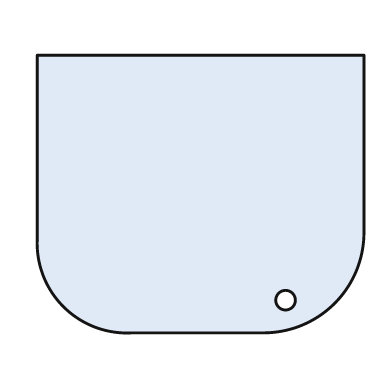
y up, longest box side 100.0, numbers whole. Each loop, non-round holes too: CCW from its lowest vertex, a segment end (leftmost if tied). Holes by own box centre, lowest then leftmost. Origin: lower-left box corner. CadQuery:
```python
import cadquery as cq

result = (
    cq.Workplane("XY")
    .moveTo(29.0, 0.0)
    .lineTo(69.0, 0.0)
    .threePointArc((91.0, 9.0), (100.0, 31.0))
    .lineTo(100.0, 85.0)
    .lineTo(0.0, 85.0)
    .lineTo(0.0, 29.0)
    .threePointArc((8.0, 8.0), (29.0, 0.0))
    .close()
    .moveTo(76.0, 10.0)
    .circle(3.0)
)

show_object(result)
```